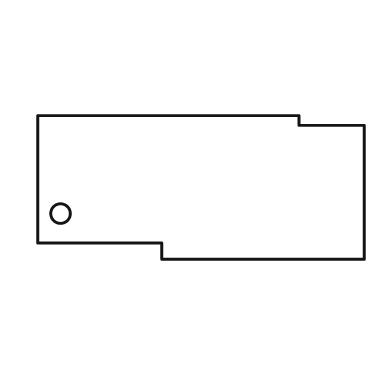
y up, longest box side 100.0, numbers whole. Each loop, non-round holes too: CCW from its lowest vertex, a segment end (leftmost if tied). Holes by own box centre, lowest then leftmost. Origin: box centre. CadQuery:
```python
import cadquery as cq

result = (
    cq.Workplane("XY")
    .moveTo(-12.0, -22.0)
    .lineTo(50.0, -22.0)
    .lineTo(50.0, 19.0)
    .lineTo(30.0, 19.0)
    .lineTo(30.0, 22.0)
    .lineTo(-50.0, 22.0)
    .lineTo(-50.0, -17.0)
    .lineTo(-12.0, -17.0)
    .close()
    .moveTo(-43.0, -8.0)
    .circle(3.0)
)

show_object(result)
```